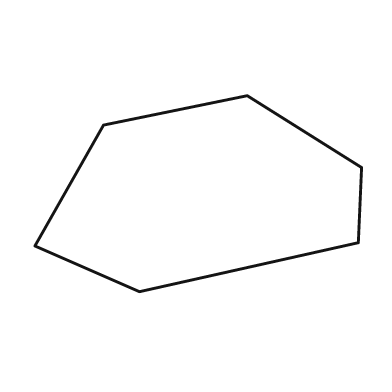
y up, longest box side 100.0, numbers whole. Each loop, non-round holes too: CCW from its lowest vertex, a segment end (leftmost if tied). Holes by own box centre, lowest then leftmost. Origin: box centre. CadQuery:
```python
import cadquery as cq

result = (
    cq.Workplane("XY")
    .moveTo(-18.0, -30.0)
    .lineTo(49.0, -15.0)
    .lineTo(50.0, 8.0)
    .lineTo(15.0, 30.0)
    .lineTo(-29.0, 21.0)
    .lineTo(-50.0, -16.0)
    .close()
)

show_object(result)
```